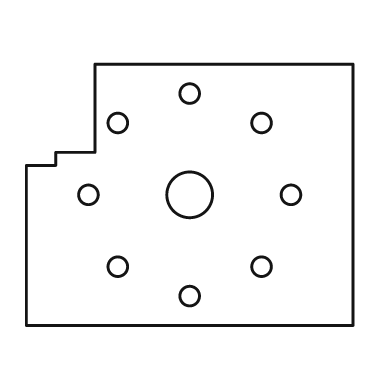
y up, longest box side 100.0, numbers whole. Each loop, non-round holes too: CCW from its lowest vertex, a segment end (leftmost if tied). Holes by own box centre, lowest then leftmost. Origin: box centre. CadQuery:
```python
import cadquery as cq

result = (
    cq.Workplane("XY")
    .moveTo(-50.0, -40.0)
    .lineTo(50.0, -40.0)
    .lineTo(50.0, 40.0)
    .lineTo(-29.0, 40.0)
    .lineTo(-29.0, 13.0)
    .lineTo(-41.0, 13.0)
    .lineTo(-41.0, 9.0)
    .lineTo(-50.0, 9.0)
    .close()
    .moveTo(0.0, -31.0)
    .circle(3.0)
    .moveTo(-22.0, -22.0)
    .circle(3.0)
    .moveTo(22.0, -22.0)
    .circle(3.0)
    .moveTo(-31.0, 0.0)
    .circle(3.0)
    .moveTo(0.0, 0.0)
    .circle(7.0)
    .moveTo(31.0, 0.0)
    .circle(3.0)
    .moveTo(-22.0, 22.0)
    .circle(3.0)
    .moveTo(22.0, 22.0)
    .circle(3.0)
    .moveTo(0.0, 31.0)
    .circle(3.0)
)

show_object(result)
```